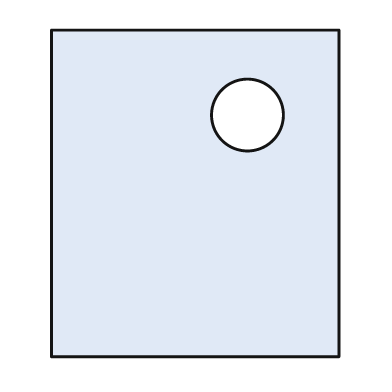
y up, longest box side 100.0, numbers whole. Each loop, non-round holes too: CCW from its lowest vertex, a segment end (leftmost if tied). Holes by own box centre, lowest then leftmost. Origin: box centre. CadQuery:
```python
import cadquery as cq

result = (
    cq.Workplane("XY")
    .moveTo(-44.0, -50.0)
    .lineTo(44.0, -50.0)
    .lineTo(44.0, 50.0)
    .lineTo(-44.0, 50.0)
    .close()
    .moveTo(16.0, 24.0)
    .circle(11.0)
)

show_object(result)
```